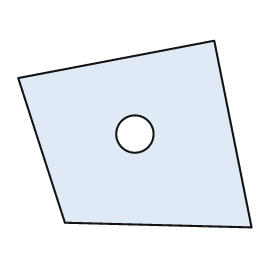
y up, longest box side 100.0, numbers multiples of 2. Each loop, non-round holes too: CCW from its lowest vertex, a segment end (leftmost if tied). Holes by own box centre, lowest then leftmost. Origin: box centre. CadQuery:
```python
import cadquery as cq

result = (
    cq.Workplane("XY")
    .moveTo(50.0, -40.0)
    .lineTo(34.0, 40.0)
    .lineTo(-50.0, 24.0)
    .lineTo(-30.0, -38.0)
    .close()
    .moveTo(0.0, 0.0)
    .circle(8.0)
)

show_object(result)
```